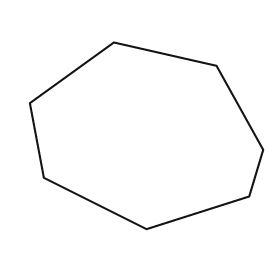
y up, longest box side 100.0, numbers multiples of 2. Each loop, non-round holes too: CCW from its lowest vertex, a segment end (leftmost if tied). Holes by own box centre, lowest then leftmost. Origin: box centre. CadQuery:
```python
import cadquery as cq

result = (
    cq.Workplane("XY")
    .moveTo(0.0, -40.0)
    .lineTo(44.0, -26.0)
    .lineTo(50.0, -6.0)
    .lineTo(30.0, 30.0)
    .lineTo(-14.0, 40.0)
    .lineTo(-50.0, 14.0)
    .lineTo(-44.0, -18.0)
    .close()
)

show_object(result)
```